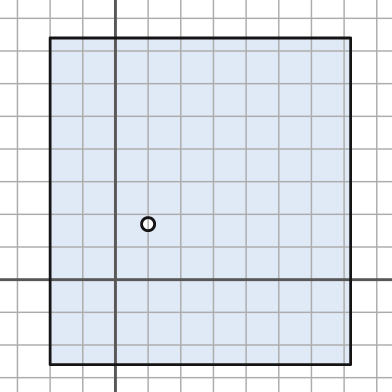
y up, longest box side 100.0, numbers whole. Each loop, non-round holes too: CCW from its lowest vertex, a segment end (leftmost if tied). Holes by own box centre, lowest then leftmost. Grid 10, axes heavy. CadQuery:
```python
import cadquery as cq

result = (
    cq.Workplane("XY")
    .moveTo(-20.0, -26.0)
    .lineTo(72.0, -26.0)
    .lineTo(72.0, 74.0)
    .lineTo(-20.0, 74.0)
    .close()
    .moveTo(10.0, 17.0)
    .circle(2.0)
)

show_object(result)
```